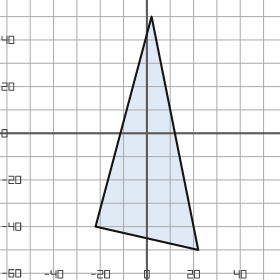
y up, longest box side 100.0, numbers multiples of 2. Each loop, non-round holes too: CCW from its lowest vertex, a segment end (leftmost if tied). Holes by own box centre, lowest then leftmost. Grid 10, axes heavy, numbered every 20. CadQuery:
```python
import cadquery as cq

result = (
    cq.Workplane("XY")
    .moveTo(22.0, -50.0)
    .lineTo(2.0, 50.0)
    .lineTo(-22.0, -40.0)
    .close()
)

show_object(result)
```